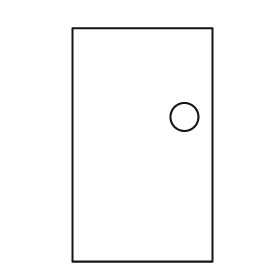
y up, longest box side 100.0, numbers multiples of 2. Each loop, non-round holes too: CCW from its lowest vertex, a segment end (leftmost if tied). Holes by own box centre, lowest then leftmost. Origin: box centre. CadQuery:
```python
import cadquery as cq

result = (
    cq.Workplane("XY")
    .moveTo(-30.0, -50.0)
    .lineTo(30.0, -50.0)
    .lineTo(30.0, 50.0)
    .lineTo(-30.0, 50.0)
    .close()
    .moveTo(18.0, 12.0)
    .circle(6.0)
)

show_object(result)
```